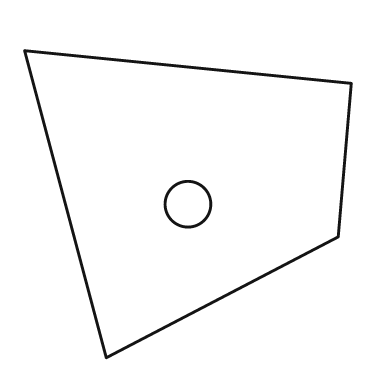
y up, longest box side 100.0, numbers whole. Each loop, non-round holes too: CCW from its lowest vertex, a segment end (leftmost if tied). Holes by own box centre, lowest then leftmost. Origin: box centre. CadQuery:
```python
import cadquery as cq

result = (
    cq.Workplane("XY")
    .moveTo(-25.0, -47.0)
    .lineTo(46.0, -10.0)
    .lineTo(50.0, 37.0)
    .lineTo(-50.0, 47.0)
    .close()
    .moveTo(0.0, 0.0)
    .circle(7.0)
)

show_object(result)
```